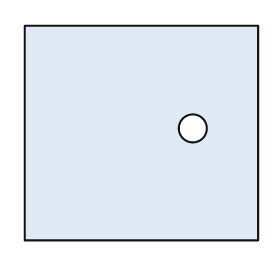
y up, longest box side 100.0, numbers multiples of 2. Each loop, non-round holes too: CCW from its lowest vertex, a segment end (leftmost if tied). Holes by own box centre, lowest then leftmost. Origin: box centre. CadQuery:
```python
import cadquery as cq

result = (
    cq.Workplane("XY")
    .moveTo(-50.0, -46.0)
    .lineTo(50.0, -46.0)
    .lineTo(50.0, 46.0)
    .lineTo(-50.0, 46.0)
    .close()
    .moveTo(22.0, 2.0)
    .circle(6.0)
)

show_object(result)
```